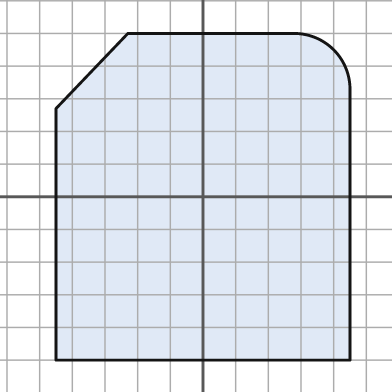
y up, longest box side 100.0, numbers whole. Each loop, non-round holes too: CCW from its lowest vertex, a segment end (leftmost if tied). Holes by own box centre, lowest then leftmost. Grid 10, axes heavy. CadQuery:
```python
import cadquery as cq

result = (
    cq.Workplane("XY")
    .moveTo(-45.0, -50.0)
    .lineTo(45.0, -50.0)
    .lineTo(45.0, 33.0)
    .threePointArc((40.0, 45.0), (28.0, 50.0))
    .lineTo(-23.0, 50.0)
    .lineTo(-45.0, 27.0)
    .close()
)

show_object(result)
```